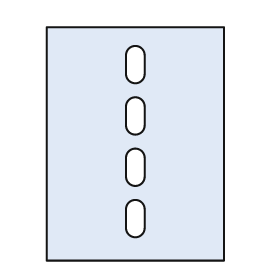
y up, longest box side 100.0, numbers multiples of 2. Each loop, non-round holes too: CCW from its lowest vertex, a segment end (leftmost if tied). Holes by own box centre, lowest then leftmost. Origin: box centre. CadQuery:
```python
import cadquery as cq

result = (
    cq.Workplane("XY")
    .moveTo(-38.0, -50.0)
    .lineTo(38.0, -50.0)
    .lineTo(38.0, 50.0)
    .lineTo(-38.0, 50.0)
    .close()
    .moveTo(-4.0, -36.0)
    .threePointArc((0.0, -40.0), (4.0, -36.0))
    .lineTo(4.0, -28.0)
    .threePointArc((0.0, -24.0), (-4.0, -28.0))
    .close()
    .moveTo(-4.0, -14.0)
    .threePointArc((0.0, -18.0), (4.0, -14.0))
    .lineTo(4.0, -6.0)
    .threePointArc((0.0, -2.0), (-4.0, -6.0))
    .close()
    .moveTo(-4.0, 8.0)
    .threePointArc((0.0, 4.0), (4.0, 8.0))
    .lineTo(4.0, 16.0)
    .threePointArc((0.0, 20.0), (-4.0, 16.0))
    .close()
    .moveTo(-4.0, 30.0)
    .threePointArc((0.0, 26.0), (4.0, 30.0))
    .lineTo(4.0, 38.0)
    .threePointArc((0.0, 42.0), (-4.0, 38.0))
    .close()
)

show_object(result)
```